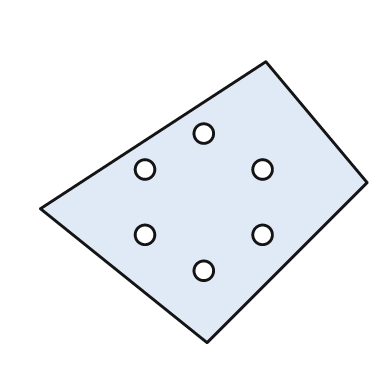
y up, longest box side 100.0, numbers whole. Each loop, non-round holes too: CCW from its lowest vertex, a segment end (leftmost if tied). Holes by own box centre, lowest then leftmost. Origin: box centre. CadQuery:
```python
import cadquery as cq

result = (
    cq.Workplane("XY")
    .moveTo(1.0, -43.0)
    .lineTo(50.0, 6.0)
    .lineTo(19.0, 43.0)
    .lineTo(-50.0, -2.0)
    .close()
    .moveTo(0.0, -21.0)
    .circle(3.0)
    .moveTo(-18.0, -10.0)
    .circle(3.0)
    .moveTo(18.0, -10.0)
    .circle(3.0)
    .moveTo(-18.0, 10.0)
    .circle(3.0)
    .moveTo(18.0, 10.0)
    .circle(3.0)
    .moveTo(0.0, 21.0)
    .circle(3.0)
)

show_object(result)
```